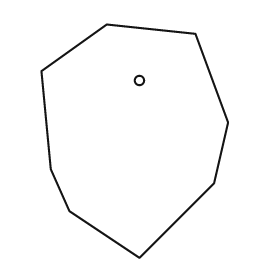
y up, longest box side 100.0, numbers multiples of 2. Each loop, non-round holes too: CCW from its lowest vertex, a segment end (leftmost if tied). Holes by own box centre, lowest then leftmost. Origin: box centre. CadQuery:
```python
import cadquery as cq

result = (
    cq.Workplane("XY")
    .moveTo(2.0, -50.0)
    .lineTo(34.0, -18.0)
    .lineTo(40.0, 8.0)
    .lineTo(26.0, 46.0)
    .lineTo(-12.0, 50.0)
    .lineTo(-40.0, 30.0)
    .lineTo(-36.0, -12.0)
    .lineTo(-28.0, -30.0)
    .close()
    .moveTo(2.0, 26.0)
    .circle(2.0)
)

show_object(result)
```